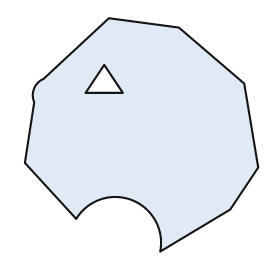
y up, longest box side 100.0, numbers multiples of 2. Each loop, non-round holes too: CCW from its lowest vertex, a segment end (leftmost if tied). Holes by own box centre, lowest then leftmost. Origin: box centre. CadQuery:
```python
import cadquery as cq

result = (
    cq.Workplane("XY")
    .moveTo(8.0, -50.0)
    .lineTo(38.0, -32.0)
    .lineTo(50.0, -14.0)
    .lineTo(44.0, 22.0)
    .lineTo(16.0, 46.0)
    .lineTo(-14.0, 50.0)
    .lineTo(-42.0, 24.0)
    .threePointArc((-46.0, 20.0), (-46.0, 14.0))
    .lineTo(-50.0, -12.0)
    .lineTo(-28.0, -36.0)
    .threePointArc((-4.0, -28.0), (8.0, -50.0))
    .close()
    .moveTo(-24.0, 18.0)
    .lineTo(-8.0, 18.0)
    .lineTo(-16.0, 30.0)
    .close()
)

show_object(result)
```